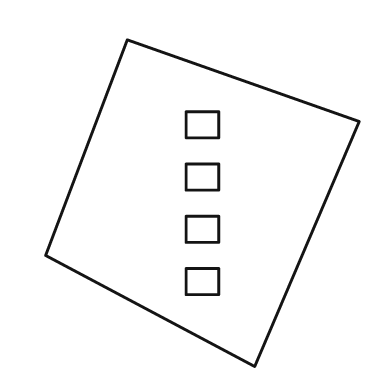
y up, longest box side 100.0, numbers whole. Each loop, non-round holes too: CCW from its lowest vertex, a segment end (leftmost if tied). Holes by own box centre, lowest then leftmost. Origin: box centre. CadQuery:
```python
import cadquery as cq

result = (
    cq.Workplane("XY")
    .moveTo(16.0, -50.0)
    .lineTo(48.0, 25.0)
    .lineTo(-23.0, 50.0)
    .lineTo(-48.0, -16.0)
    .close()
    .moveTo(-5.0, -28.0)
    .lineTo(5.0, -28.0)
    .lineTo(5.0, -20.0)
    .lineTo(-5.0, -20.0)
    .close()
    .moveTo(-5.0, -12.0)
    .lineTo(5.0, -12.0)
    .lineTo(5.0, -4.0)
    .lineTo(-5.0, -4.0)
    .close()
    .moveTo(-5.0, 4.0)
    .lineTo(5.0, 4.0)
    .lineTo(5.0, 12.0)
    .lineTo(-5.0, 12.0)
    .close()
    .moveTo(-5.0, 20.0)
    .lineTo(5.0, 20.0)
    .lineTo(5.0, 28.0)
    .lineTo(-5.0, 28.0)
    .close()
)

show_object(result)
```